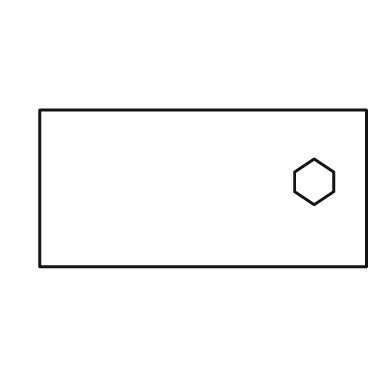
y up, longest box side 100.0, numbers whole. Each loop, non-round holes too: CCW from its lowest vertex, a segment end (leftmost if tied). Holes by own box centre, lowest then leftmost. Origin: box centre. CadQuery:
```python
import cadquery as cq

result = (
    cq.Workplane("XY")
    .moveTo(-50.0, -24.0)
    .lineTo(50.0, -24.0)
    .lineTo(50.0, 24.0)
    .lineTo(-50.0, 24.0)
    .close()
    .moveTo(34.0, -5.0)
    .lineTo(40.0, -1.0)
    .lineTo(40.0, 5.0)
    .lineTo(34.0, 9.0)
    .lineTo(28.0, 5.0)
    .lineTo(28.0, -1.0)
    .close()
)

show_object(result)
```